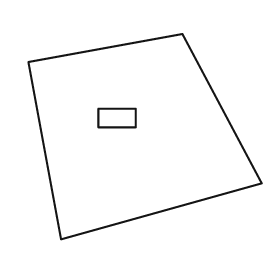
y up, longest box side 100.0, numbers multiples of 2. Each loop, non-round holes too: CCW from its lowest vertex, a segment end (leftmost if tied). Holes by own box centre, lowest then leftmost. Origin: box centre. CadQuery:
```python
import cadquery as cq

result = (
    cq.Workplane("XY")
    .moveTo(-36.0, -44.0)
    .lineTo(50.0, -20.0)
    .lineTo(16.0, 44.0)
    .lineTo(-50.0, 32.0)
    .close()
    .moveTo(-20.0, 4.0)
    .lineTo(-4.0, 4.0)
    .lineTo(-4.0, 12.0)
    .lineTo(-20.0, 12.0)
    .close()
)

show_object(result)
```